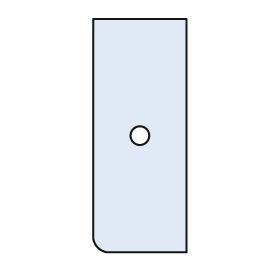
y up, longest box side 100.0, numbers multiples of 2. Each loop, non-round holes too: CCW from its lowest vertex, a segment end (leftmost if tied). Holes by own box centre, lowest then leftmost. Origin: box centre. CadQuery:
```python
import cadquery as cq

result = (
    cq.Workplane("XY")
    .moveTo(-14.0, -50.0)
    .lineTo(20.0, -50.0)
    .lineTo(20.0, 50.0)
    .lineTo(-20.0, 50.0)
    .lineTo(-20.0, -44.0)
    .threePointArc((-18.0, -48.0), (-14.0, -50.0))
    .close()
    .moveTo(0.0, 0.0)
    .circle(4.0)
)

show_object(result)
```